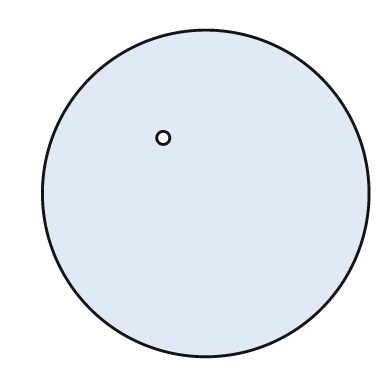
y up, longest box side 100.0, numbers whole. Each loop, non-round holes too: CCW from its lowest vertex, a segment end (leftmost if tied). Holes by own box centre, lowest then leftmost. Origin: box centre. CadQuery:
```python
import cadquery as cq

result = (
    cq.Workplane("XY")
    .moveTo(0.0, 0.0)
    .circle(50.0)
    .moveTo(-13.0, 17.0)
    .circle(2.0)
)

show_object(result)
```